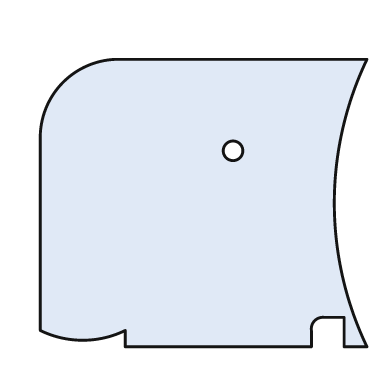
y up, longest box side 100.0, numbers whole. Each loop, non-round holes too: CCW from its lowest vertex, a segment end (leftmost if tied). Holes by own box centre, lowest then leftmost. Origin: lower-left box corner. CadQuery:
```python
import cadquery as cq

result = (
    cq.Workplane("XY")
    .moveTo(26.0, 0.0)
    .lineTo(83.0, 0.0)
    .lineTo(83.0, 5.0)
    .threePointArc((84.0, 8.0), (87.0, 9.0))
    .lineTo(93.0, 9.0)
    .lineTo(93.0, 0.0)
    .lineTo(100.0, 0.0)
    .threePointArc((90.0, 44.0), (100.0, 88.0))
    .lineTo(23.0, 88.0)
    .threePointArc((7.0, 81.0), (0.0, 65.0))
    .lineTo(0.0, 5.0)
    .threePointArc((13.0, 2.0), (26.0, 5.0))
    .close()
    .moveTo(59.0, 60.0)
    .circle(3.0)
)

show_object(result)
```